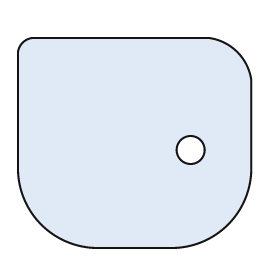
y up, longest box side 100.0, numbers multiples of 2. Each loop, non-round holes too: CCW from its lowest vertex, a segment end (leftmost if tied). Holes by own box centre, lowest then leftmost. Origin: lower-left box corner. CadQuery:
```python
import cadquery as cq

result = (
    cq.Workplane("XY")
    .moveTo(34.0, 0.0)
    .lineTo(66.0, 0.0)
    .threePointArc((90.0, 10.0), (100.0, 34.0))
    .lineTo(100.0, 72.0)
    .threePointArc((94.0, 84.0), (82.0, 90.0))
    .lineTo(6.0, 90.0)
    .threePointArc((2.0, 88.0), (0.0, 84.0))
    .lineTo(0.0, 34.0)
    .threePointArc((10.0, 10.0), (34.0, 0.0))
    .close()
    .moveTo(74.0, 42.0)
    .circle(6.0)
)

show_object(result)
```